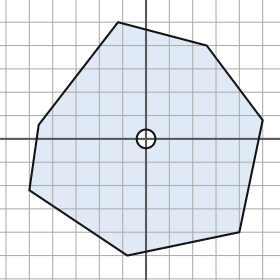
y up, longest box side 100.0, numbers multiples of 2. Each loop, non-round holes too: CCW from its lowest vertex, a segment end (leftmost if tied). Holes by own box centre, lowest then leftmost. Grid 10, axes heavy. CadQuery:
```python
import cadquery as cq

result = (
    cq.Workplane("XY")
    .moveTo(-8.0, -50.0)
    .lineTo(40.0, -40.0)
    .lineTo(50.0, 8.0)
    .lineTo(26.0, 40.0)
    .lineTo(-12.0, 50.0)
    .lineTo(-46.0, 6.0)
    .lineTo(-50.0, -22.0)
    .close()
    .moveTo(0.0, 0.0)
    .circle(4.0)
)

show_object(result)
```